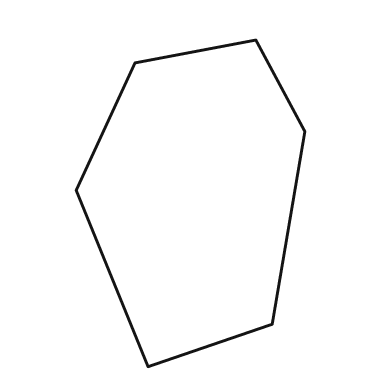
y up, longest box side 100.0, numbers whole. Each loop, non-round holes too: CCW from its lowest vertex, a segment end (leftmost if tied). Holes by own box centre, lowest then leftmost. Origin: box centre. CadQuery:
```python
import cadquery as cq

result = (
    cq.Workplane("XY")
    .moveTo(-13.0, -50.0)
    .lineTo(25.0, -37.0)
    .lineTo(35.0, 22.0)
    .lineTo(20.0, 50.0)
    .lineTo(-17.0, 43.0)
    .lineTo(-35.0, 4.0)
    .close()
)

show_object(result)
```